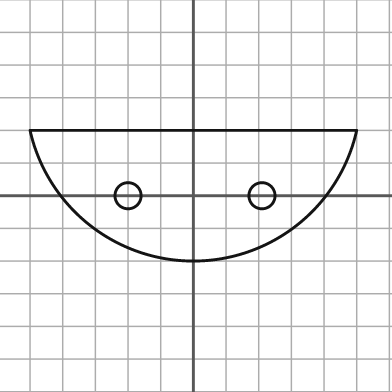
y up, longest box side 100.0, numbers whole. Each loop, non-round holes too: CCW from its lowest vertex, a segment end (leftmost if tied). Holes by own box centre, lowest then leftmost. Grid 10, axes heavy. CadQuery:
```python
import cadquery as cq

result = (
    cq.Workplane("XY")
    .moveTo(-50.0, 20.0)
    .threePointArc((0.0, -20.0), (50.0, 20.0))
    .close()
    .moveTo(-20.0, 0.0)
    .circle(4.0)
    .moveTo(21.0, 0.0)
    .circle(4.0)
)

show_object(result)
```